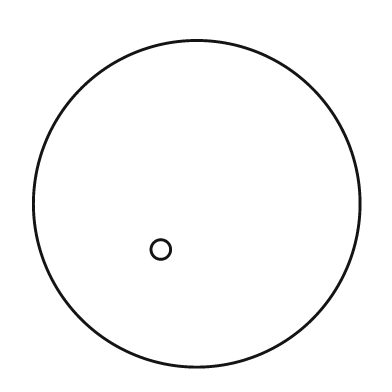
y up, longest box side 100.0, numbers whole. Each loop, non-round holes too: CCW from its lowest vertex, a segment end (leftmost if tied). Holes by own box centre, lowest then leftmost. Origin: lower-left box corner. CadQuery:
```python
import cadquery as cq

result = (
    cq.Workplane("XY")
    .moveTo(50.0, 50.0)
    .circle(50.0)
    .moveTo(39.0, 36.0)
    .circle(3.0)
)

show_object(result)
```